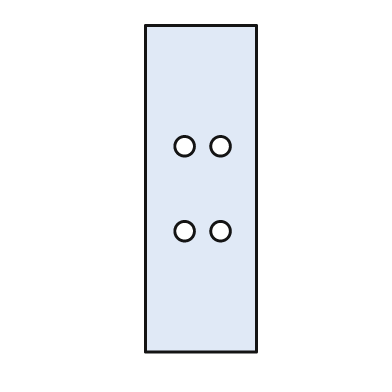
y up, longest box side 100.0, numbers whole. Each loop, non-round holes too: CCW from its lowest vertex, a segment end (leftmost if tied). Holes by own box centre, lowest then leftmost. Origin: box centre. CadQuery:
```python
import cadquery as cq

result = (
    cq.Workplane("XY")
    .moveTo(-17.0, -50.0)
    .lineTo(17.0, -50.0)
    .lineTo(17.0, 50.0)
    .lineTo(-17.0, 50.0)
    .close()
    .moveTo(-5.0, -13.0)
    .circle(3.0)
    .moveTo(6.0, -13.0)
    .circle(3.0)
    .moveTo(-5.0, 13.0)
    .circle(3.0)
    .moveTo(6.0, 13.0)
    .circle(3.0)
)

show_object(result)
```